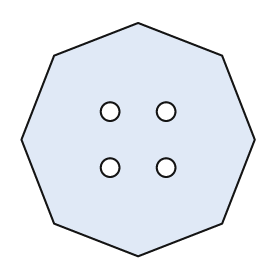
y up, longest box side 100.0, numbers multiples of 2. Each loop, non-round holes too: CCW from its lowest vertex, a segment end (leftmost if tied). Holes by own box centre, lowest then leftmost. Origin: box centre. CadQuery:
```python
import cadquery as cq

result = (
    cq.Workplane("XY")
    .moveTo(0.0, -50.0)
    .lineTo(36.0, -36.0)
    .lineTo(50.0, 0.0)
    .lineTo(36.0, 36.0)
    .lineTo(0.0, 50.0)
    .lineTo(-36.0, 36.0)
    .lineTo(-50.0, 0.0)
    .lineTo(-36.0, -36.0)
    .close()
    .moveTo(-12.0, -12.0)
    .circle(4.0)
    .moveTo(12.0, -12.0)
    .circle(4.0)
    .moveTo(-12.0, 12.0)
    .circle(4.0)
    .moveTo(12.0, 12.0)
    .circle(4.0)
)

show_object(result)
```